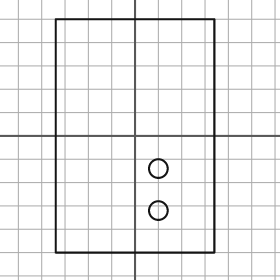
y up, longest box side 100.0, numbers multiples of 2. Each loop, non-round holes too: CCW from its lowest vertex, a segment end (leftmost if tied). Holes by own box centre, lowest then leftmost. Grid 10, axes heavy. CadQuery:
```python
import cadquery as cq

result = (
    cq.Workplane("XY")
    .moveTo(-34.0, -50.0)
    .lineTo(34.0, -50.0)
    .lineTo(34.0, 50.0)
    .lineTo(-34.0, 50.0)
    .close()
    .moveTo(10.0, -32.0)
    .circle(4.0)
    .moveTo(10.0, -14.0)
    .circle(4.0)
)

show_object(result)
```